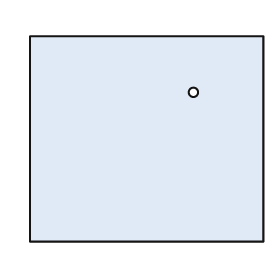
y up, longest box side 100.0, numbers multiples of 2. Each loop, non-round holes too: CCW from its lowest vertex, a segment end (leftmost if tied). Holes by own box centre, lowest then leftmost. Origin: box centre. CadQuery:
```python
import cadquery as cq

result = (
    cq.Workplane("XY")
    .moveTo(-50.0, -44.0)
    .lineTo(50.0, -44.0)
    .lineTo(50.0, 44.0)
    .lineTo(-50.0, 44.0)
    .close()
    .moveTo(20.0, 20.0)
    .circle(2.0)
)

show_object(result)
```